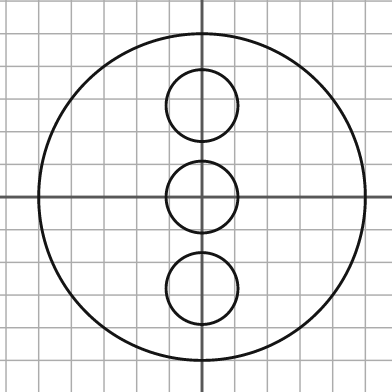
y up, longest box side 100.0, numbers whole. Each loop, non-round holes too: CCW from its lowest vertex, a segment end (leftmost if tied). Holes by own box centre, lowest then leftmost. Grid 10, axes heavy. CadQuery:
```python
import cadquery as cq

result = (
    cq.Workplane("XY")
    .moveTo(0.0, 0.0)
    .circle(50.0)
    .moveTo(0.0, -28.0)
    .circle(11.0)
    .moveTo(0.0, 0.0)
    .circle(11.0)
    .moveTo(0.0, 28.0)
    .circle(11.0)
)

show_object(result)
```